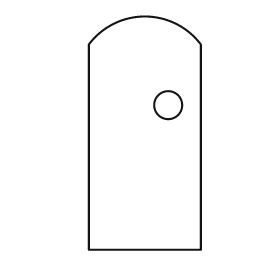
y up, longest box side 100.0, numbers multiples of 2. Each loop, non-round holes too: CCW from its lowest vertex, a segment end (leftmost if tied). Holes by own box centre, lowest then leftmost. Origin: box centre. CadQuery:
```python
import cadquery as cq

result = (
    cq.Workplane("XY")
    .moveTo(-24.0, -50.0)
    .lineTo(24.0, -50.0)
    .lineTo(24.0, 38.0)
    .threePointArc((0.0, 50.0), (-24.0, 38.0))
    .close()
    .moveTo(10.0, 12.0)
    .circle(6.0)
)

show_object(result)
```